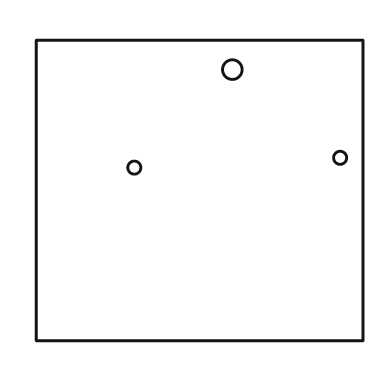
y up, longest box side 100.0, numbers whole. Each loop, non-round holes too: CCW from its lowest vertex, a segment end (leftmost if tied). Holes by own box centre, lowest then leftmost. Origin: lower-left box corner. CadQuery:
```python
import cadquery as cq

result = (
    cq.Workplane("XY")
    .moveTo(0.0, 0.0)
    .lineTo(100.0, 0.0)
    .lineTo(100.0, 92.0)
    .lineTo(0.0, 92.0)
    .close()
    .moveTo(30.0, 53.0)
    .circle(2.0)
    .moveTo(93.0, 56.0)
    .circle(2.0)
    .moveTo(60.0, 83.0)
    .circle(3.0)
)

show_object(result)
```